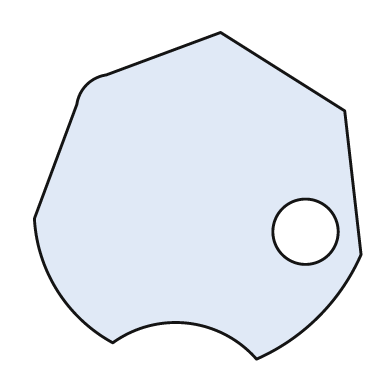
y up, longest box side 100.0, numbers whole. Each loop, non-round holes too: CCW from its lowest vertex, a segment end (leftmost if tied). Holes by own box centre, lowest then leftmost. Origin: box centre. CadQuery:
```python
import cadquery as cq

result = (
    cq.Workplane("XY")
    .moveTo(18.0, -50.0)
    .threePointArc((37.0, -37.0), (50.0, -18.0))
    .lineTo(45.0, 26.0)
    .lineTo(7.0, 50.0)
    .lineTo(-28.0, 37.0)
    .threePointArc((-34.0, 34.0), (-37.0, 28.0))
    .lineTo(-50.0, -7.0)
    .threePointArc((-43.0, -29.0), (-26.0, -45.0))
    .threePointArc((-3.0, -39.0), (18.0, -50.0))
    .close()
    .moveTo(33.0, -11.0)
    .circle(10.0)
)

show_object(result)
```